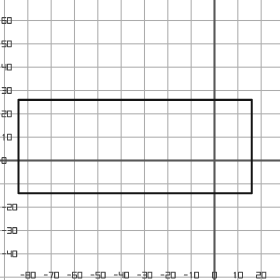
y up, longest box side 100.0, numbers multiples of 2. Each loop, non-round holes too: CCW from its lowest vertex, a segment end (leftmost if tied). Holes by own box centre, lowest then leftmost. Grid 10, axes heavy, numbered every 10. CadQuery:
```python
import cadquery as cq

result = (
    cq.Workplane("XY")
    .moveTo(-84.0, -14.0)
    .lineTo(16.0, -14.0)
    .lineTo(16.0, 26.0)
    .lineTo(-84.0, 26.0)
    .close()
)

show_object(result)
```